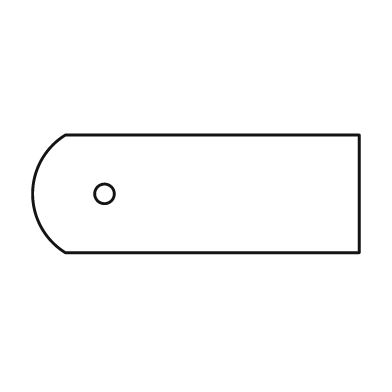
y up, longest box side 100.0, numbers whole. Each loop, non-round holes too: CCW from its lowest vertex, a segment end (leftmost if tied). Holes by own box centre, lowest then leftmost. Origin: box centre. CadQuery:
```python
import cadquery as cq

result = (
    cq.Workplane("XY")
    .moveTo(-40.0, -18.0)
    .lineTo(50.0, -18.0)
    .lineTo(50.0, 18.0)
    .lineTo(-40.0, 18.0)
    .threePointArc((-50.0, 0.0), (-40.0, -18.0))
    .close()
    .moveTo(-28.0, 0.0)
    .circle(3.0)
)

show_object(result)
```